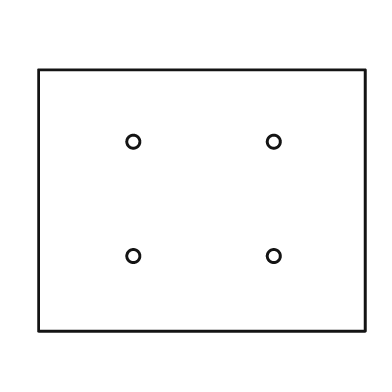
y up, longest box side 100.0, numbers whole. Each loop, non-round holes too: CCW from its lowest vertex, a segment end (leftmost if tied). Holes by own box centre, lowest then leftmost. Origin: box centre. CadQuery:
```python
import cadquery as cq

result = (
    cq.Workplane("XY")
    .moveTo(-50.0, -40.0)
    .lineTo(50.0, -40.0)
    .lineTo(50.0, 40.0)
    .lineTo(-50.0, 40.0)
    .close()
    .moveTo(-21.0, -17.0)
    .circle(2.0)
    .moveTo(22.0, -17.0)
    .circle(2.0)
    .moveTo(-21.0, 18.0)
    .circle(2.0)
    .moveTo(22.0, 18.0)
    .circle(2.0)
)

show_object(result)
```